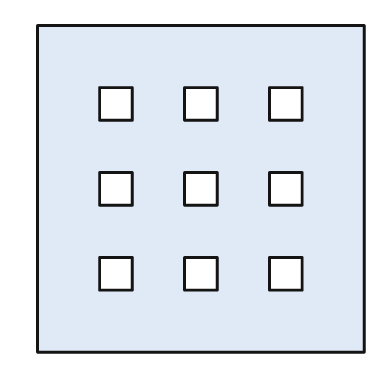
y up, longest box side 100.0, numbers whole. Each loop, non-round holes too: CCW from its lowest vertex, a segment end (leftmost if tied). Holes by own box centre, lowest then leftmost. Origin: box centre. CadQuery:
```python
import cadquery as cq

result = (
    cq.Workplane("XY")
    .moveTo(-50.0, -50.0)
    .lineTo(50.0, -50.0)
    .lineTo(50.0, 50.0)
    .lineTo(-50.0, 50.0)
    .close()
    .moveTo(-31.0, -31.0)
    .lineTo(-21.0, -31.0)
    .lineTo(-21.0, -21.0)
    .lineTo(-31.0, -21.0)
    .close()
    .moveTo(-5.0, -31.0)
    .lineTo(5.0, -31.0)
    .lineTo(5.0, -21.0)
    .lineTo(-5.0, -21.0)
    .close()
    .moveTo(21.0, -31.0)
    .lineTo(31.0, -31.0)
    .lineTo(31.0, -21.0)
    .lineTo(21.0, -21.0)
    .close()
    .moveTo(-31.0, -5.0)
    .lineTo(-21.0, -5.0)
    .lineTo(-21.0, 5.0)
    .lineTo(-31.0, 5.0)
    .close()
    .moveTo(-5.0, -5.0)
    .lineTo(5.0, -5.0)
    .lineTo(5.0, 5.0)
    .lineTo(-5.0, 5.0)
    .close()
    .moveTo(21.0, -5.0)
    .lineTo(31.0, -5.0)
    .lineTo(31.0, 5.0)
    .lineTo(21.0, 5.0)
    .close()
    .moveTo(-31.0, 21.0)
    .lineTo(-21.0, 21.0)
    .lineTo(-21.0, 31.0)
    .lineTo(-31.0, 31.0)
    .close()
    .moveTo(-5.0, 21.0)
    .lineTo(5.0, 21.0)
    .lineTo(5.0, 31.0)
    .lineTo(-5.0, 31.0)
    .close()
    .moveTo(21.0, 21.0)
    .lineTo(31.0, 21.0)
    .lineTo(31.0, 31.0)
    .lineTo(21.0, 31.0)
    .close()
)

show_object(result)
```